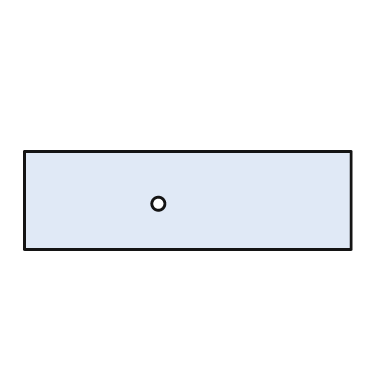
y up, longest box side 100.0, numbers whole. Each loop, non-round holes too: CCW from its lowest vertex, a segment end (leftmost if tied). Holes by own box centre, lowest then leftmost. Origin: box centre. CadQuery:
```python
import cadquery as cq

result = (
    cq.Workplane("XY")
    .moveTo(-50.0, -15.0)
    .lineTo(50.0, -15.0)
    .lineTo(50.0, 15.0)
    .lineTo(-50.0, 15.0)
    .close()
    .moveTo(-9.0, -1.0)
    .circle(2.0)
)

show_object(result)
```